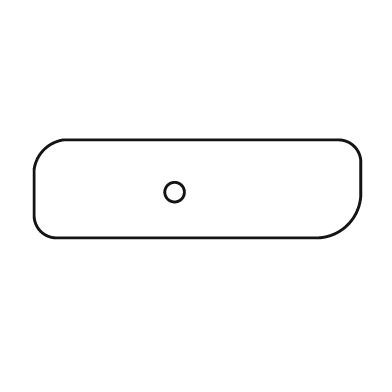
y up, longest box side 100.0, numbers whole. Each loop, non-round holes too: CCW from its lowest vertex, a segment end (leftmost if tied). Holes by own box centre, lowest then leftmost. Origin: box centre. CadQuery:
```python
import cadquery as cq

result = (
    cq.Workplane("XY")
    .moveTo(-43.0, -15.0)
    .lineTo(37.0, -15.0)
    .threePointArc((46.0, -11.0), (50.0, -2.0))
    .lineTo(50.0, 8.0)
    .threePointArc((48.0, 13.0), (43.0, 15.0))
    .lineTo(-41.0, 15.0)
    .threePointArc((-47.0, 12.0), (-50.0, 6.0))
    .lineTo(-50.0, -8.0)
    .threePointArc((-48.0, -13.0), (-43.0, -15.0))
    .close()
    .moveTo(-7.0, -1.0)
    .circle(3.0)
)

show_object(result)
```